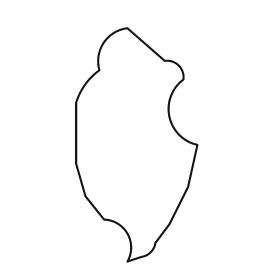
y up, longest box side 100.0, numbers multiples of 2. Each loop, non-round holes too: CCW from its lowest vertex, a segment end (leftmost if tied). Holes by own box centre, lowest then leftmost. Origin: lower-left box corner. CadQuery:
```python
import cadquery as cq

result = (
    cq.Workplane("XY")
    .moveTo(22.0, 0.0)
    .lineTo(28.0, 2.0)
    .threePointArc((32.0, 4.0), (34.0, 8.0))
    .lineTo(40.0, 16.0)
    .lineTo(48.0, 32.0)
    .lineTo(52.0, 50.0)
    .threePointArc((40.0, 62.0), (46.0, 78.0))
    .threePointArc((44.0, 84.0), (38.0, 86.0))
    .lineTo(22.0, 100.0)
    .threePointArc((12.0, 94.0), (10.0, 82.0))
    .threePointArc((4.0, 76.0), (0.0, 68.0))
    .lineTo(0.0, 42.0)
    .lineTo(4.0, 28.0)
    .lineTo(12.0, 18.0)
    .threePointArc((22.0, 12.0), (22.0, 0.0))
    .close()
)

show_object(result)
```